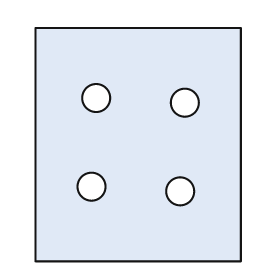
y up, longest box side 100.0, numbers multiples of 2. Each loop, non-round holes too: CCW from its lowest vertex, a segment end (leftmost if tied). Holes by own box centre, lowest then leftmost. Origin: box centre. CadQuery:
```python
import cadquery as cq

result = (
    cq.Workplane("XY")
    .moveTo(-44.0, -50.0)
    .lineTo(44.0, -50.0)
    .lineTo(44.0, 50.0)
    .lineTo(-44.0, 50.0)
    .close()
    .moveTo(18.0, -20.0)
    .circle(6.0)
    .moveTo(-20.0, -18.0)
    .circle(6.0)
    .moveTo(20.0, 18.0)
    .circle(6.0)
    .moveTo(-18.0, 20.0)
    .circle(6.0)
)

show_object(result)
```